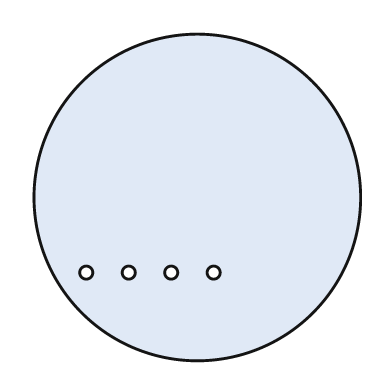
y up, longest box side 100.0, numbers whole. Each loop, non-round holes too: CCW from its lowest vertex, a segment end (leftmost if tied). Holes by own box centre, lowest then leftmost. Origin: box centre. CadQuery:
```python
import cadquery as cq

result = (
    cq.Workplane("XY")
    .moveTo(0.0, 0.0)
    .circle(50.0)
    .moveTo(-34.0, -23.0)
    .circle(2.0)
    .moveTo(-21.0, -23.0)
    .circle(2.0)
    .moveTo(-8.0, -23.0)
    .circle(2.0)
    .moveTo(5.0, -23.0)
    .circle(2.0)
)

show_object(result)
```